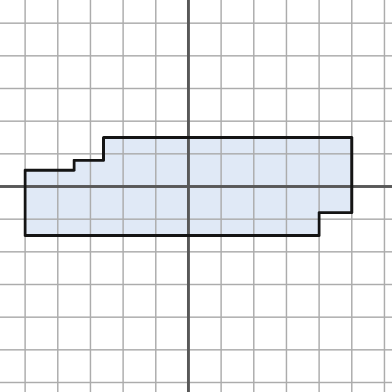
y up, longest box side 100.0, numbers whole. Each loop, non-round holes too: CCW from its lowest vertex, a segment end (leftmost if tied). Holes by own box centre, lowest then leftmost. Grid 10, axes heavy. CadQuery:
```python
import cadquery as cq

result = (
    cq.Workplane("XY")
    .moveTo(-50.0, -15.0)
    .lineTo(40.0, -15.0)
    .lineTo(40.0, -8.0)
    .lineTo(50.0, -8.0)
    .lineTo(50.0, 15.0)
    .lineTo(-26.0, 15.0)
    .lineTo(-26.0, 8.0)
    .lineTo(-35.0, 8.0)
    .lineTo(-35.0, 5.0)
    .lineTo(-50.0, 5.0)
    .close()
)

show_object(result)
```